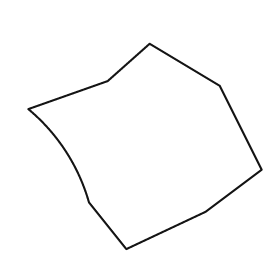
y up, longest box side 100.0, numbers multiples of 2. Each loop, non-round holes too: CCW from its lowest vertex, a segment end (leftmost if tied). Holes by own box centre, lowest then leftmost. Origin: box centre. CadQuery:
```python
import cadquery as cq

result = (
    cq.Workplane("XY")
    .moveTo(-8.0, -44.0)
    .lineTo(26.0, -28.0)
    .lineTo(50.0, -10.0)
    .lineTo(32.0, 26.0)
    .lineTo(2.0, 44.0)
    .lineTo(-16.0, 28.0)
    .lineTo(-50.0, 16.0)
    .threePointArc((-34.0, -2.0), (-24.0, -24.0))
    .close()
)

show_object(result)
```